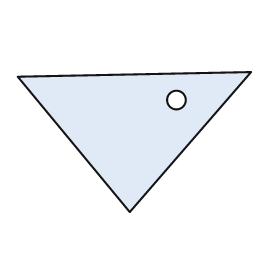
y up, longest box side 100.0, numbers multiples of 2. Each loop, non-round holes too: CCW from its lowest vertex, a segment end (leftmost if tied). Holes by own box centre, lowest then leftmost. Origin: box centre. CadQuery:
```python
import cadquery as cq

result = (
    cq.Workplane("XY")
    .moveTo(-2.0, -30.0)
    .lineTo(50.0, 30.0)
    .lineTo(-50.0, 28.0)
    .close()
    .moveTo(18.0, 18.0)
    .circle(4.0)
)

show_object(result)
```